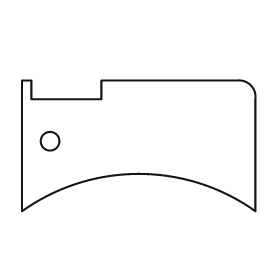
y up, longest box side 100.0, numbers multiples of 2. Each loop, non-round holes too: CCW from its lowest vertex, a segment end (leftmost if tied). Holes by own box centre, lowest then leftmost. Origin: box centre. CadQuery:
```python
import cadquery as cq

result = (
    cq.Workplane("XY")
    .moveTo(-50.0, -28.0)
    .threePointArc((0.0, -12.0), (50.0, -28.0))
    .lineTo(50.0, 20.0)
    .threePointArc((48.0, 26.0), (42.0, 28.0))
    .lineTo(-16.0, 28.0)
    .lineTo(-16.0, 20.0)
    .lineTo(-46.0, 20.0)
    .lineTo(-46.0, 28.0)
    .lineTo(-50.0, 28.0)
    .close()
    .moveTo(-38.0, 2.0)
    .circle(4.0)
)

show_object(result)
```